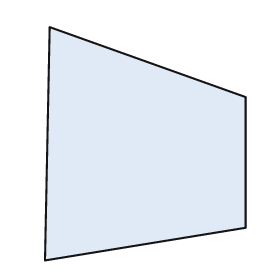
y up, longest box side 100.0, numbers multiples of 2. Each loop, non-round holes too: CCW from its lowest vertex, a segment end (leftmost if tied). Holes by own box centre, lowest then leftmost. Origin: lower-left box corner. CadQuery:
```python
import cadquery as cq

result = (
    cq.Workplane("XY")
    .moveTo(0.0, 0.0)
    .lineTo(86.0, 14.0)
    .lineTo(86.0, 70.0)
    .lineTo(2.0, 100.0)
    .close()
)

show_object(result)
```